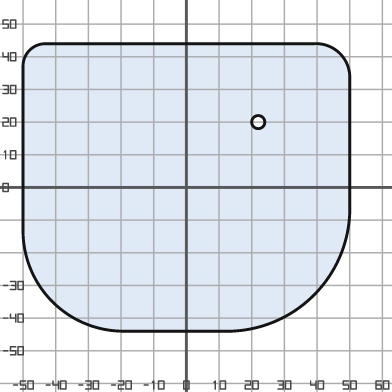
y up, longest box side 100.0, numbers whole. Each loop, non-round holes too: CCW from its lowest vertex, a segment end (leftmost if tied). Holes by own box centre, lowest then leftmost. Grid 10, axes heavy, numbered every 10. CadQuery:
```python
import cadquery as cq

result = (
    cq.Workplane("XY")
    .moveTo(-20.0, -44.0)
    .lineTo(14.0, -44.0)
    .threePointArc((39.0, -33.0), (50.0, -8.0))
    .lineTo(50.0, 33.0)
    .threePointArc((47.0, 41.0), (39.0, 44.0))
    .lineTo(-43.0, 44.0)
    .threePointArc((-48.0, 42.0), (-50.0, 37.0))
    .lineTo(-50.0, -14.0)
    .threePointArc((-41.0, -35.0), (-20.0, -44.0))
    .close()
    .moveTo(22.0, 20.0)
    .circle(2.0)
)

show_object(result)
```